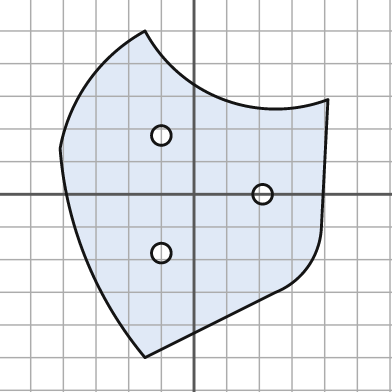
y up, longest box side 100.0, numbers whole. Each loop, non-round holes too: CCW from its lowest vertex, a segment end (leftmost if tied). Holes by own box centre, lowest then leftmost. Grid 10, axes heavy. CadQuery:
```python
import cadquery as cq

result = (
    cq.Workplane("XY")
    .moveTo(-15.0, -50.0)
    .lineTo(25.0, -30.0)
    .threePointArc((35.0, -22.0), (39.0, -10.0))
    .lineTo(41.0, 29.0)
    .threePointArc((9.0, 29.0), (-15.0, 50.0))
    .threePointArc((-32.0, 35.0), (-41.0, 14.0))
    .threePointArc((-33.0, -20.0), (-15.0, -50.0))
    .close()
    .moveTo(-10.0, -18.0)
    .circle(3.0)
    .moveTo(21.0, 0.0)
    .circle(3.0)
    .moveTo(-10.0, 18.0)
    .circle(3.0)
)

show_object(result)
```